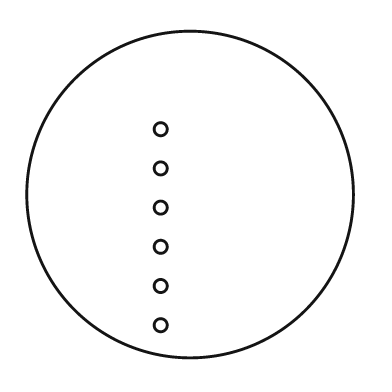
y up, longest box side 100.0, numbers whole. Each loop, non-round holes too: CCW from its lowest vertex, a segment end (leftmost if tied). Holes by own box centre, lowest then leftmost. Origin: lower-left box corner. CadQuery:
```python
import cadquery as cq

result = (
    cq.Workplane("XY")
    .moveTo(50.0, 50.0)
    .circle(50.0)
    .moveTo(41.0, 10.0)
    .circle(2.0)
    .moveTo(41.0, 22.0)
    .circle(2.0)
    .moveTo(41.0, 34.0)
    .circle(2.0)
    .moveTo(41.0, 46.0)
    .circle(2.0)
    .moveTo(41.0, 58.0)
    .circle(2.0)
    .moveTo(41.0, 70.0)
    .circle(2.0)
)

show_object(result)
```